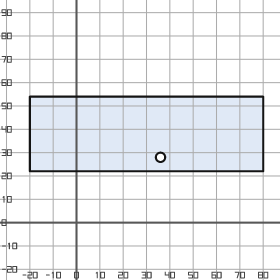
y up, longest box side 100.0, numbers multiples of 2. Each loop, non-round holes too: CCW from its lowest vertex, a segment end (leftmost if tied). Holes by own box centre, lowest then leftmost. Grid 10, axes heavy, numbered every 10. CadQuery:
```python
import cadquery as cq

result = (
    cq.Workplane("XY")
    .moveTo(-20.0, 22.0)
    .lineTo(80.0, 22.0)
    .lineTo(80.0, 54.0)
    .lineTo(-20.0, 54.0)
    .close()
    .moveTo(36.0, 28.0)
    .circle(2.0)
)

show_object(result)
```